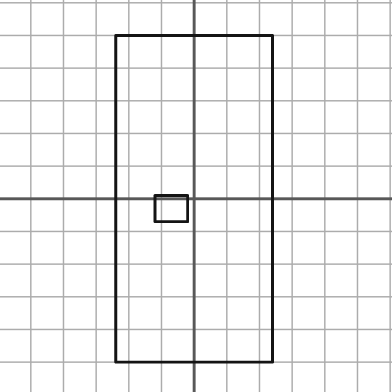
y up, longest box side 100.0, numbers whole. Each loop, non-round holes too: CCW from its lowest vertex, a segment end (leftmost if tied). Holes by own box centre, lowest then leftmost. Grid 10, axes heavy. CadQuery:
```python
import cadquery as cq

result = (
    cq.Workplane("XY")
    .moveTo(-24.0, -50.0)
    .lineTo(24.0, -50.0)
    .lineTo(24.0, 50.0)
    .lineTo(-24.0, 50.0)
    .close()
    .moveTo(-12.0, -7.0)
    .lineTo(-2.0, -7.0)
    .lineTo(-2.0, 1.0)
    .lineTo(-12.0, 1.0)
    .close()
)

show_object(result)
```